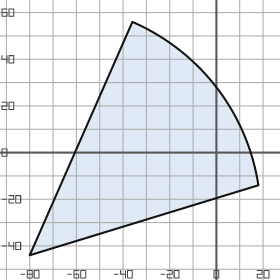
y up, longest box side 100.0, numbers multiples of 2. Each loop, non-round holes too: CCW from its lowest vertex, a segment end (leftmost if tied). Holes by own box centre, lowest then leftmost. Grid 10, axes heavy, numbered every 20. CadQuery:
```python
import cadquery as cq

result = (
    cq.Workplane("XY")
    .moveTo(-80.0, -44.0)
    .lineTo(18.0, -14.0)
    .threePointArc((0.0, 28.0), (-36.0, 56.0))
    .close()
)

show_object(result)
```